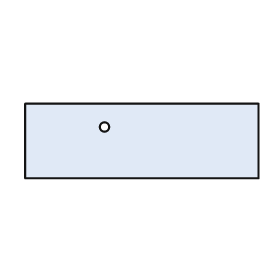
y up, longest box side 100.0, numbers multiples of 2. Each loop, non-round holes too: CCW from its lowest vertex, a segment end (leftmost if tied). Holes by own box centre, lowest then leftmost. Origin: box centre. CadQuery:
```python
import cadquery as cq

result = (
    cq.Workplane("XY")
    .moveTo(-50.0, -16.0)
    .lineTo(50.0, -16.0)
    .lineTo(50.0, 16.0)
    .lineTo(-50.0, 16.0)
    .close()
    .moveTo(-16.0, 6.0)
    .circle(2.0)
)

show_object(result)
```